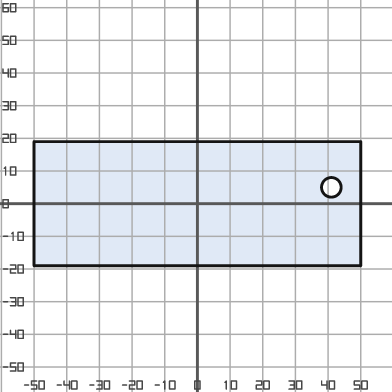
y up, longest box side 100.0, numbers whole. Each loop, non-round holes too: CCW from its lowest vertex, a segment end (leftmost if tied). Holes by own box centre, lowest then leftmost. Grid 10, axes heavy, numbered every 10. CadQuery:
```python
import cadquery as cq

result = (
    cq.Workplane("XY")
    .moveTo(-50.0, -19.0)
    .lineTo(50.0, -19.0)
    .lineTo(50.0, 19.0)
    .lineTo(-50.0, 19.0)
    .close()
    .moveTo(41.0, 5.0)
    .circle(3.0)
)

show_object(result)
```